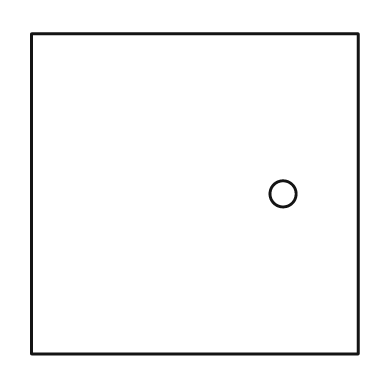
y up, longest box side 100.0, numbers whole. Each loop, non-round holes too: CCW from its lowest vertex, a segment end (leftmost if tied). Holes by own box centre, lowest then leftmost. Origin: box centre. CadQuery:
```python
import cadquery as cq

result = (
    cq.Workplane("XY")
    .moveTo(-50.0, -49.0)
    .lineTo(50.0, -49.0)
    .lineTo(50.0, 49.0)
    .lineTo(-50.0, 49.0)
    .close()
    .moveTo(27.0, 0.0)
    .circle(4.0)
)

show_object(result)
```